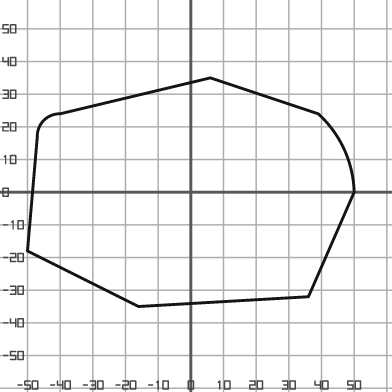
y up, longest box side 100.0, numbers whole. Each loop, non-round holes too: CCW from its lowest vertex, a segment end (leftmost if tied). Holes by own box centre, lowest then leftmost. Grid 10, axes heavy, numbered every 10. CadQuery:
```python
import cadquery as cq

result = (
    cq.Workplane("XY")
    .moveTo(-16.0, -35.0)
    .lineTo(36.0, -32.0)
    .lineTo(50.0, 0.0)
    .threePointArc((47.0, 13.0), (39.0, 24.0))
    .lineTo(6.0, 35.0)
    .lineTo(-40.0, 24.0)
    .threePointArc((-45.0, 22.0), (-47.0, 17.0))
    .lineTo(-50.0, -18.0)
    .close()
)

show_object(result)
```